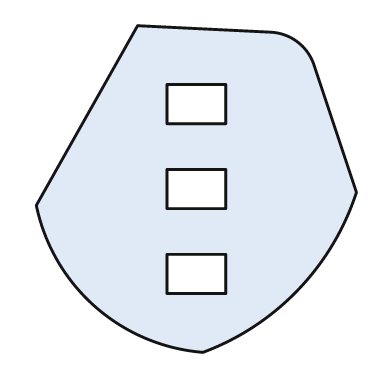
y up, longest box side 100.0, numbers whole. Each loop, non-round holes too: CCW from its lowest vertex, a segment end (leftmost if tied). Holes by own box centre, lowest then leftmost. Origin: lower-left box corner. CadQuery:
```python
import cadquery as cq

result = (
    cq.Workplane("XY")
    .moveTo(51.0, 0.0)
    .threePointArc((80.0, 19.0), (98.0, 49.0))
    .lineTo(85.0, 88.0)
    .threePointArc((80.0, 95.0), (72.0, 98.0))
    .lineTo(31.0, 100.0)
    .lineTo(0.0, 45.0)
    .threePointArc((18.0, 14.0), (51.0, 0.0))
    .close()
    .moveTo(40.0, 18.0)
    .lineTo(58.0, 18.0)
    .lineTo(58.0, 30.0)
    .lineTo(40.0, 30.0)
    .close()
    .moveTo(40.0, 44.0)
    .lineTo(58.0, 44.0)
    .lineTo(58.0, 56.0)
    .lineTo(40.0, 56.0)
    .close()
    .moveTo(40.0, 70.0)
    .lineTo(58.0, 70.0)
    .lineTo(58.0, 82.0)
    .lineTo(40.0, 82.0)
    .close()
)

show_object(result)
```